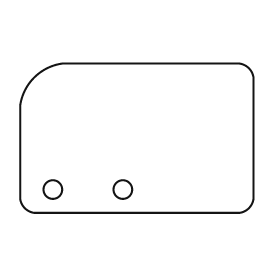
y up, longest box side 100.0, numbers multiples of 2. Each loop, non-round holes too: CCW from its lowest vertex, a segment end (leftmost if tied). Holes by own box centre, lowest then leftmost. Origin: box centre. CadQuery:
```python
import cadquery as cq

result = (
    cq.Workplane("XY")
    .moveTo(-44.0, -32.0)
    .lineTo(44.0, -32.0)
    .threePointArc((48.0, -30.0), (50.0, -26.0))
    .lineTo(50.0, 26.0)
    .threePointArc((48.0, 30.0), (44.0, 32.0))
    .lineTo(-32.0, 32.0)
    .threePointArc((-44.0, 26.0), (-50.0, 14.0))
    .lineTo(-50.0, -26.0)
    .threePointArc((-48.0, -30.0), (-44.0, -32.0))
    .close()
    .moveTo(-36.0, -22.0)
    .circle(4.0)
    .moveTo(-6.0, -22.0)
    .circle(4.0)
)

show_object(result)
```